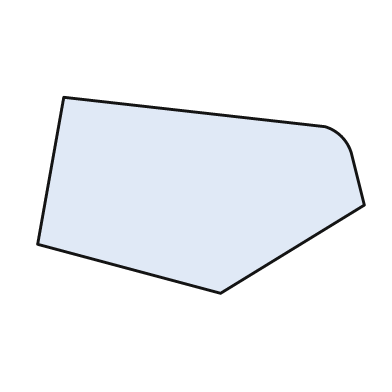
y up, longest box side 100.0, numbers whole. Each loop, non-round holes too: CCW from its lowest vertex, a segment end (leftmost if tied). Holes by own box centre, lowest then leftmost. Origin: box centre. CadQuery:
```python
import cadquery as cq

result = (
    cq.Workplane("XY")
    .moveTo(6.0, -30.0)
    .lineTo(50.0, -3.0)
    .lineTo(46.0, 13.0)
    .threePointArc((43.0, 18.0), (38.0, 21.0))
    .lineTo(-42.0, 30.0)
    .lineTo(-50.0, -15.0)
    .close()
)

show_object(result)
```